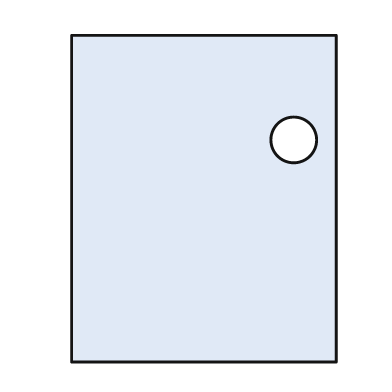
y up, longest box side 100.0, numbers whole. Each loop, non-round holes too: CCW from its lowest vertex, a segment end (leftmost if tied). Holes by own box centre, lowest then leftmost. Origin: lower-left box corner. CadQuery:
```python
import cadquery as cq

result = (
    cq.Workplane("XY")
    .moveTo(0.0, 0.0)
    .lineTo(81.0, 0.0)
    .lineTo(81.0, 100.0)
    .lineTo(0.0, 100.0)
    .close()
    .moveTo(68.0, 68.0)
    .circle(7.0)
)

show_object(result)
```